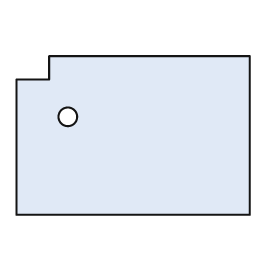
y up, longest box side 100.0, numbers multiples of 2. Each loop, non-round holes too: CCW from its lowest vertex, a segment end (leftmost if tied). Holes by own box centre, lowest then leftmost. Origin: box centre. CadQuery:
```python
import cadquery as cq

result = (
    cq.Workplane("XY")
    .moveTo(-50.0, -34.0)
    .lineTo(50.0, -34.0)
    .lineTo(50.0, 34.0)
    .lineTo(-36.0, 34.0)
    .lineTo(-36.0, 24.0)
    .lineTo(-50.0, 24.0)
    .close()
    .moveTo(-28.0, 8.0)
    .circle(4.0)
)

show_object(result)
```